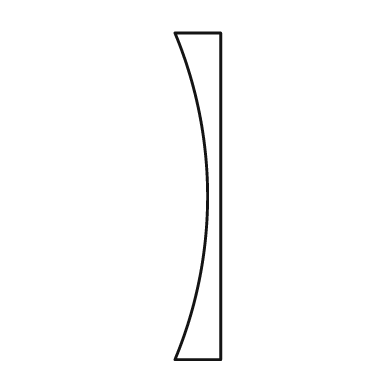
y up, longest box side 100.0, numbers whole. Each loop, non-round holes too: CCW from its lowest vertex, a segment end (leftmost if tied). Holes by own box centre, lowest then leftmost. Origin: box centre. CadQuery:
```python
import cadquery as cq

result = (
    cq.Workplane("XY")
    .moveTo(-7.0, -50.0)
    .lineTo(7.0, -50.0)
    .lineTo(7.0, 50.0)
    .lineTo(-7.0, 50.0)
    .threePointArc((3.0, 0.0), (-7.0, -50.0))
    .close()
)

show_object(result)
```